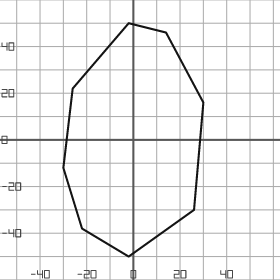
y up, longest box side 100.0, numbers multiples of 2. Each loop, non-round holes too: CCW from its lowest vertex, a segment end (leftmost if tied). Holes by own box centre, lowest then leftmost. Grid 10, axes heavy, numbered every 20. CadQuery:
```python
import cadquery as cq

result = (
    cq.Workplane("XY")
    .moveTo(-2.0, -50.0)
    .lineTo(26.0, -30.0)
    .lineTo(30.0, 16.0)
    .lineTo(14.0, 46.0)
    .lineTo(-2.0, 50.0)
    .lineTo(-26.0, 22.0)
    .lineTo(-30.0, -12.0)
    .lineTo(-22.0, -38.0)
    .close()
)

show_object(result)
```